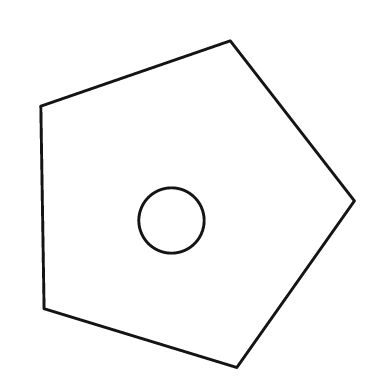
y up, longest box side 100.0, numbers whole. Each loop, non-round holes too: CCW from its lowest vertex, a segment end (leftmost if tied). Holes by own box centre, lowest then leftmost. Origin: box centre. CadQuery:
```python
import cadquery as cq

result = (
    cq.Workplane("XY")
    .moveTo(12.0, -50.0)
    .lineTo(48.0, 1.0)
    .lineTo(10.0, 50.0)
    .lineTo(-48.0, 30.0)
    .lineTo(-47.0, -32.0)
    .close()
    .moveTo(-8.0, -5.0)
    .circle(10.0)
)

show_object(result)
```